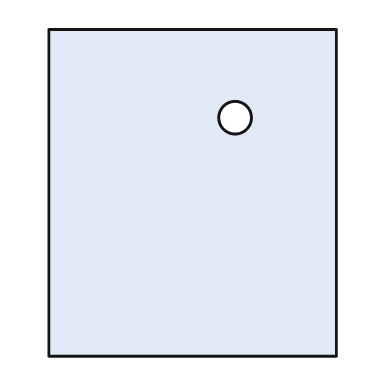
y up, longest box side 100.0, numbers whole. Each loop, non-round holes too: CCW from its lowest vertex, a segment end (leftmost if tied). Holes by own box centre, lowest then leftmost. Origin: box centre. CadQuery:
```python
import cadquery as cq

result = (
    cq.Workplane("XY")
    .moveTo(-44.0, -50.0)
    .lineTo(44.0, -50.0)
    .lineTo(44.0, 50.0)
    .lineTo(-44.0, 50.0)
    .close()
    .moveTo(13.0, 23.0)
    .circle(5.0)
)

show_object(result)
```